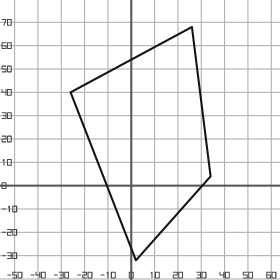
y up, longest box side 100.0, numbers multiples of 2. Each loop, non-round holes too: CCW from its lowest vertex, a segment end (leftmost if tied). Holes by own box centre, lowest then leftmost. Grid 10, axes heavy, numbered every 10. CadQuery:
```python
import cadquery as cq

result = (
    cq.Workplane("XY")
    .moveTo(2.0, -32.0)
    .lineTo(34.0, 4.0)
    .lineTo(26.0, 68.0)
    .lineTo(-26.0, 40.0)
    .close()
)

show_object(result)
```